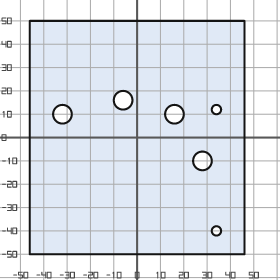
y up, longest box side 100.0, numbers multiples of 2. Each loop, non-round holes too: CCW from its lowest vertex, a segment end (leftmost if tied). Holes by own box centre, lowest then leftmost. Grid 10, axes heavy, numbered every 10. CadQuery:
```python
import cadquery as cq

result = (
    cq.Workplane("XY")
    .moveTo(-46.0, -50.0)
    .lineTo(46.0, -50.0)
    .lineTo(46.0, 50.0)
    .lineTo(-46.0, 50.0)
    .close()
    .moveTo(34.0, -40.0)
    .circle(2.0)
    .moveTo(28.0, -10.0)
    .circle(4.0)
    .moveTo(-32.0, 10.0)
    .circle(4.0)
    .moveTo(16.0, 10.0)
    .circle(4.0)
    .moveTo(34.0, 12.0)
    .circle(2.0)
    .moveTo(-6.0, 16.0)
    .circle(4.0)
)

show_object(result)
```